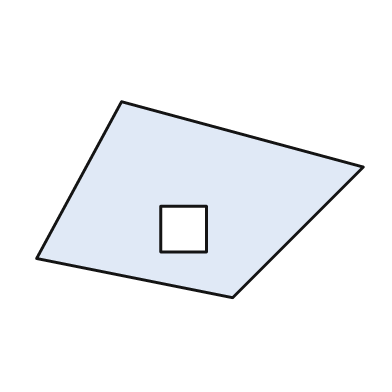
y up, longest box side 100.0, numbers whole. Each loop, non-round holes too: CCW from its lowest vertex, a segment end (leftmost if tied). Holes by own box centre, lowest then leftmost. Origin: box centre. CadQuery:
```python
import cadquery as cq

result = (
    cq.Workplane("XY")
    .moveTo(10.0, -30.0)
    .lineTo(50.0, 10.0)
    .lineTo(-24.0, 30.0)
    .lineTo(-50.0, -18.0)
    .close()
    .moveTo(-12.0, -16.0)
    .lineTo(2.0, -16.0)
    .lineTo(2.0, -2.0)
    .lineTo(-12.0, -2.0)
    .close()
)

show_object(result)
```